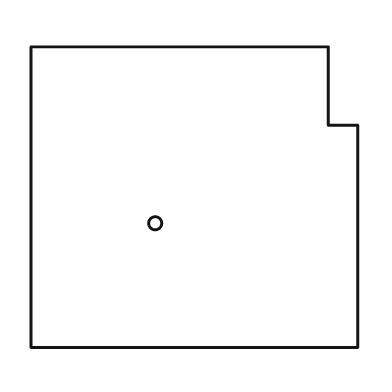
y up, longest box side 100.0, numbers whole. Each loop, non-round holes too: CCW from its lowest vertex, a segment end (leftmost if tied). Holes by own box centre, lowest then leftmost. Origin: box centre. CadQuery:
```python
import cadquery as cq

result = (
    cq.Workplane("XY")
    .moveTo(-50.0, -46.0)
    .lineTo(50.0, -46.0)
    .lineTo(50.0, 22.0)
    .lineTo(41.0, 22.0)
    .lineTo(41.0, 46.0)
    .lineTo(-50.0, 46.0)
    .close()
    .moveTo(-12.0, -8.0)
    .circle(2.0)
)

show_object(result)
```